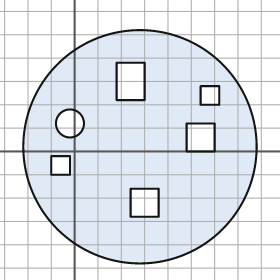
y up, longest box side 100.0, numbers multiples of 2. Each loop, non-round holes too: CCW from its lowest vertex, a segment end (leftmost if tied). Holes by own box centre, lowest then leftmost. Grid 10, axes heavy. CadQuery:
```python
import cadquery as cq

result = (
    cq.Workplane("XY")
    .moveTo(28.0, 2.0)
    .circle(50.0)
    .moveTo(24.0, -28.0)
    .lineTo(36.0, -28.0)
    .lineTo(36.0, -16.0)
    .lineTo(24.0, -16.0)
    .close()
    .moveTo(-10.0, -10.0)
    .lineTo(-2.0, -10.0)
    .lineTo(-2.0, -2.0)
    .lineTo(-10.0, -2.0)
    .close()
    .moveTo(48.0, 0.0)
    .lineTo(60.0, 0.0)
    .lineTo(60.0, 12.0)
    .lineTo(48.0, 12.0)
    .close()
    .moveTo(-2.0, 12.0)
    .circle(6.0)
    .moveTo(54.0, 20.0)
    .lineTo(62.0, 20.0)
    .lineTo(62.0, 28.0)
    .lineTo(54.0, 28.0)
    .close()
    .moveTo(18.0, 22.0)
    .lineTo(30.0, 22.0)
    .lineTo(30.0, 38.0)
    .lineTo(18.0, 38.0)
    .close()
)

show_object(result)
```